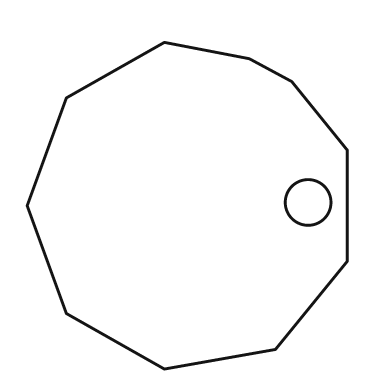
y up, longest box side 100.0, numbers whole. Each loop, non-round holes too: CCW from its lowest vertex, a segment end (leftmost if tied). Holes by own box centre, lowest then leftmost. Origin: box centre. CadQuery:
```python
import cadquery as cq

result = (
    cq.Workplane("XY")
    .moveTo(-7.0, -50.0)
    .lineTo(27.0, -44.0)
    .lineTo(49.0, -17.0)
    .lineTo(49.0, 17.0)
    .lineTo(32.0, 38.0)
    .lineTo(19.0, 45.0)
    .lineTo(-7.0, 50.0)
    .lineTo(-37.0, 33.0)
    .lineTo(-49.0, 0.0)
    .lineTo(-37.0, -33.0)
    .close()
    .moveTo(37.0, 1.0)
    .circle(7.0)
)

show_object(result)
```